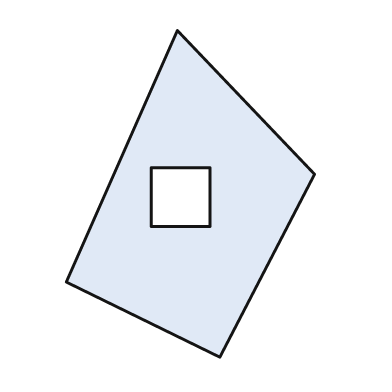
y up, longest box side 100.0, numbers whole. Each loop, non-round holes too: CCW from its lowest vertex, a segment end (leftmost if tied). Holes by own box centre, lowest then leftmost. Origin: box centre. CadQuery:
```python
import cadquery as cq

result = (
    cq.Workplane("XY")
    .moveTo(9.0, -50.0)
    .lineTo(38.0, 6.0)
    .lineTo(-4.0, 50.0)
    .lineTo(-38.0, -27.0)
    .close()
    .moveTo(-12.0, -10.0)
    .lineTo(6.0, -10.0)
    .lineTo(6.0, 8.0)
    .lineTo(-12.0, 8.0)
    .close()
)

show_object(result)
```